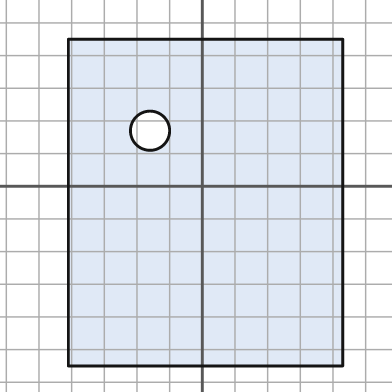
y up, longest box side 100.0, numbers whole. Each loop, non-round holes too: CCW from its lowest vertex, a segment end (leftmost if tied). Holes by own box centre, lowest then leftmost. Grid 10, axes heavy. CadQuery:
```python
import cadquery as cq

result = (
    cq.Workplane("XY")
    .moveTo(-41.0, -55.0)
    .lineTo(43.0, -55.0)
    .lineTo(43.0, 45.0)
    .lineTo(-41.0, 45.0)
    .close()
    .moveTo(-16.0, 17.0)
    .circle(6.0)
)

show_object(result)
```